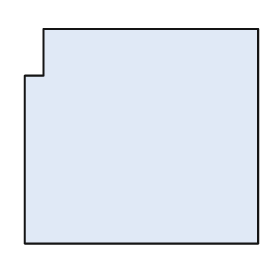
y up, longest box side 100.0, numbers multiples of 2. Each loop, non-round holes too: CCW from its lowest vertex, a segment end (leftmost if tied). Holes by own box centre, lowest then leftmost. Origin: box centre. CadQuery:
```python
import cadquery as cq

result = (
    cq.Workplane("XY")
    .moveTo(-50.0, -46.0)
    .lineTo(50.0, -46.0)
    .lineTo(50.0, 46.0)
    .lineTo(-42.0, 46.0)
    .lineTo(-42.0, 26.0)
    .lineTo(-50.0, 26.0)
    .close()
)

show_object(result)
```